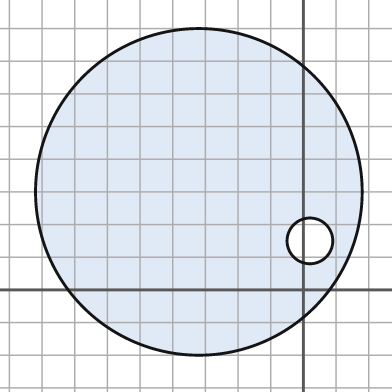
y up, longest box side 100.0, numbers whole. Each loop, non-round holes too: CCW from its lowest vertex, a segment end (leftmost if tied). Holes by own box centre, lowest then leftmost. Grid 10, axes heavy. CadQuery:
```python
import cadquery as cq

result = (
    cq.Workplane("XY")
    .moveTo(-32.0, 30.0)
    .circle(50.0)
    .moveTo(2.0, 15.0)
    .circle(7.0)
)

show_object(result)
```